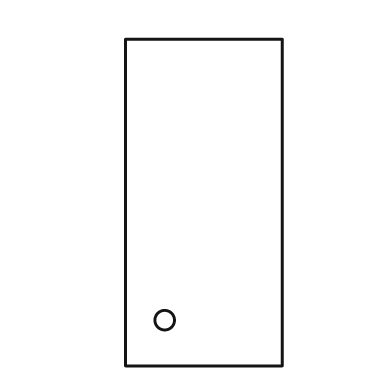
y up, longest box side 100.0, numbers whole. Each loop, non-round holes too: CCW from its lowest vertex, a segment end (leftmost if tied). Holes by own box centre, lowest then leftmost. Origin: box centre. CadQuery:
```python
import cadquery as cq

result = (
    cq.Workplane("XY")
    .moveTo(-24.0, -50.0)
    .lineTo(24.0, -50.0)
    .lineTo(24.0, 50.0)
    .lineTo(-24.0, 50.0)
    .close()
    .moveTo(-12.0, -36.0)
    .circle(3.0)
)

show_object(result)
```